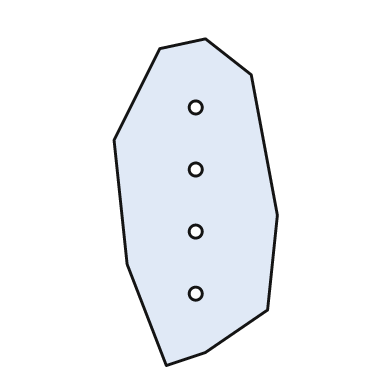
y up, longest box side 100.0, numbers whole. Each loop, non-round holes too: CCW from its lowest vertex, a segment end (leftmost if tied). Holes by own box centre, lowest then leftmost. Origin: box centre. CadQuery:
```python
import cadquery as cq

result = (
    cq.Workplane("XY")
    .moveTo(-9.0, -50.0)
    .lineTo(3.0, -46.0)
    .lineTo(22.0, -33.0)
    .lineTo(25.0, -4.0)
    .lineTo(17.0, 39.0)
    .lineTo(3.0, 50.0)
    .lineTo(-11.0, 47.0)
    .lineTo(-25.0, 19.0)
    .lineTo(-21.0, -19.0)
    .close()
    .moveTo(0.0, -28.0)
    .circle(2.0)
    .moveTo(0.0, -9.0)
    .circle(2.0)
    .moveTo(0.0, 10.0)
    .circle(2.0)
    .moveTo(0.0, 29.0)
    .circle(2.0)
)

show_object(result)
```